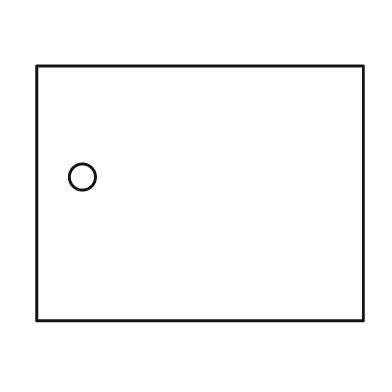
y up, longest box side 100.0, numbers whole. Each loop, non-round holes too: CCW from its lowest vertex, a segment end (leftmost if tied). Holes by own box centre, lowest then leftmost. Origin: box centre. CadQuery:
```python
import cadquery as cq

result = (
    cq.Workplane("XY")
    .moveTo(-50.0, -39.0)
    .lineTo(50.0, -39.0)
    .lineTo(50.0, 39.0)
    .lineTo(-50.0, 39.0)
    .close()
    .moveTo(-36.0, 5.0)
    .circle(4.0)
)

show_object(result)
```